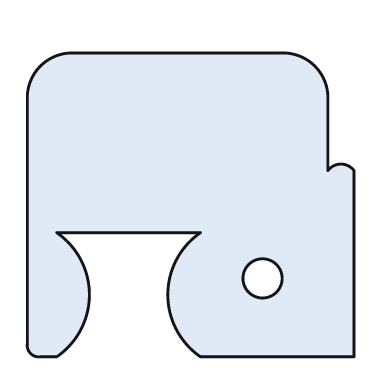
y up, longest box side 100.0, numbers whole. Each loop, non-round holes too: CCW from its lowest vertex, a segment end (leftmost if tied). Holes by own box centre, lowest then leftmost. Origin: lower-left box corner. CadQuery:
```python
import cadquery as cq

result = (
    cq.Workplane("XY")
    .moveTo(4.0, 0.0)
    .lineTo(9.0, 0.0)
    .threePointArc((19.0, 19.0), (9.0, 38.0))
    .lineTo(53.0, 38.0)
    .threePointArc((43.0, 19.0), (53.0, 0.0))
    .lineTo(100.0, 0.0)
    .lineTo(100.0, 57.0)
    .threePointArc((96.0, 59.0), (92.0, 57.0))
    .lineTo(92.0, 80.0)
    .threePointArc((88.0, 89.0), (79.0, 93.0))
    .lineTo(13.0, 93.0)
    .threePointArc((4.0, 89.0), (0.0, 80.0))
    .lineTo(0.0, 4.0)
    .threePointArc((1.0, 1.0), (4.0, 0.0))
    .close()
    .moveTo(72.0, 24.0)
    .circle(6.0)
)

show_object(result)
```